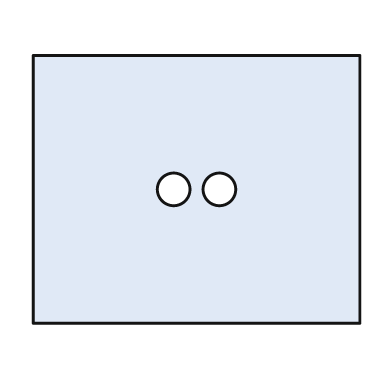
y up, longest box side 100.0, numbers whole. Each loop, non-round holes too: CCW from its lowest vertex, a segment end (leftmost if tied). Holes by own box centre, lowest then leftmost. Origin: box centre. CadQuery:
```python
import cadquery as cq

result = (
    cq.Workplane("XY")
    .moveTo(-50.0, -41.0)
    .lineTo(50.0, -41.0)
    .lineTo(50.0, 41.0)
    .lineTo(-50.0, 41.0)
    .close()
    .moveTo(-7.0, 0.0)
    .circle(5.0)
    .moveTo(7.0, 0.0)
    .circle(5.0)
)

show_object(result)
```